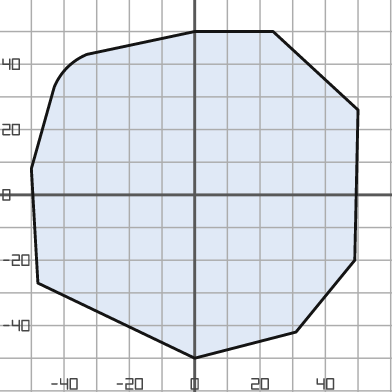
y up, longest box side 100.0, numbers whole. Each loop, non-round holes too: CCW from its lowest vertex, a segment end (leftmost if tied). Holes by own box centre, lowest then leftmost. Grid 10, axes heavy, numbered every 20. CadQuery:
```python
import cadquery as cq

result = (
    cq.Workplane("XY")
    .moveTo(0.0, -50.0)
    .lineTo(31.0, -42.0)
    .lineTo(49.0, -20.0)
    .lineTo(50.0, 26.0)
    .lineTo(24.0, 50.0)
    .lineTo(0.0, 50.0)
    .lineTo(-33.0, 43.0)
    .threePointArc((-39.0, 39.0), (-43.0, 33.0))
    .lineTo(-50.0, 8.0)
    .lineTo(-48.0, -27.0)
    .close()
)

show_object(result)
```